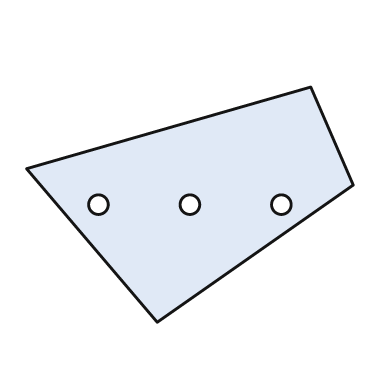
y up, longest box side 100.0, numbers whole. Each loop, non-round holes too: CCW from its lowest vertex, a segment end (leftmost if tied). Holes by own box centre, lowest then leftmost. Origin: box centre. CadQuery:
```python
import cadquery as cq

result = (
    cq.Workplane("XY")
    .moveTo(-10.0, -36.0)
    .lineTo(50.0, 6.0)
    .lineTo(37.0, 36.0)
    .lineTo(-50.0, 11.0)
    .close()
    .moveTo(-28.0, 0.0)
    .circle(3.0)
    .moveTo(0.0, 0.0)
    .circle(3.0)
    .moveTo(28.0, 0.0)
    .circle(3.0)
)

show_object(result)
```